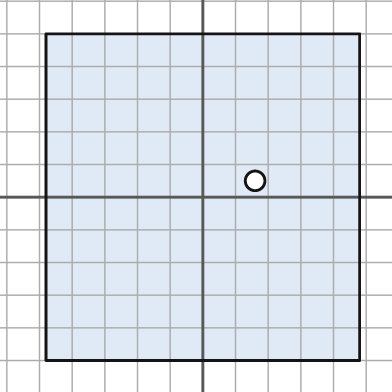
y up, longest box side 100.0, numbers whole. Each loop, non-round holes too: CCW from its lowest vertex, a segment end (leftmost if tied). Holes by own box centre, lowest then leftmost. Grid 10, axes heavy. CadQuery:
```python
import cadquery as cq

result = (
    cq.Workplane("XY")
    .moveTo(-48.0, -50.0)
    .lineTo(48.0, -50.0)
    .lineTo(48.0, 50.0)
    .lineTo(-48.0, 50.0)
    .close()
    .moveTo(16.0, 5.0)
    .circle(3.0)
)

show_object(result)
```